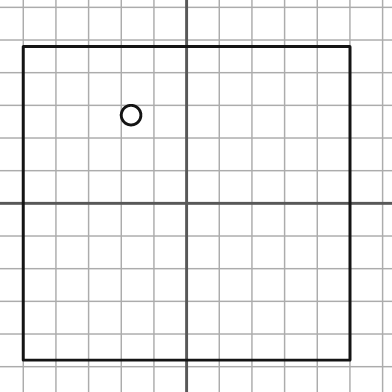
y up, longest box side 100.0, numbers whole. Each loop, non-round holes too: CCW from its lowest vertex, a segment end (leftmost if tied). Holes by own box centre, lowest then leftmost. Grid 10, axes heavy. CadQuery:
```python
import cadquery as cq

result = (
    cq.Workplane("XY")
    .moveTo(-50.0, -48.0)
    .lineTo(50.0, -48.0)
    .lineTo(50.0, 48.0)
    .lineTo(-50.0, 48.0)
    .close()
    .moveTo(-17.0, 27.0)
    .circle(3.0)
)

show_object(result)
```